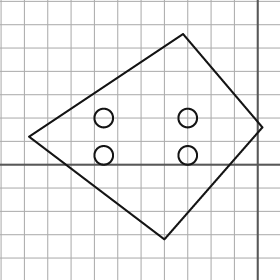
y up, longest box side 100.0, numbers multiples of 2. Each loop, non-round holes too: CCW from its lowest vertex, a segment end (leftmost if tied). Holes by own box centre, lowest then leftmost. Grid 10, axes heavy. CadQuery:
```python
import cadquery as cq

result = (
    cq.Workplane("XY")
    .moveTo(-40.0, -32.0)
    .lineTo(2.0, 16.0)
    .lineTo(-32.0, 56.0)
    .lineTo(-98.0, 12.0)
    .close()
    .moveTo(-66.0, 4.0)
    .circle(4.0)
    .moveTo(-30.0, 4.0)
    .circle(4.0)
    .moveTo(-66.0, 20.0)
    .circle(4.0)
    .moveTo(-30.0, 20.0)
    .circle(4.0)
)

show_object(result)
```